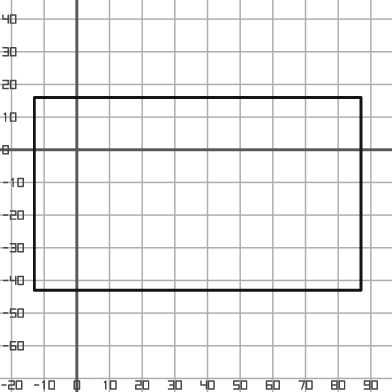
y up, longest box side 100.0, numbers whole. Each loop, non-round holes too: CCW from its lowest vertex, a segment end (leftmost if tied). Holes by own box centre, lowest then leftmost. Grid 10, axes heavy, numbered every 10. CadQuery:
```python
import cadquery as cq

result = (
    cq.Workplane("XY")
    .moveTo(-13.0, -43.0)
    .lineTo(87.0, -43.0)
    .lineTo(87.0, 16.0)
    .lineTo(-13.0, 16.0)
    .close()
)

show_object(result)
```